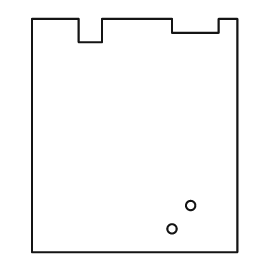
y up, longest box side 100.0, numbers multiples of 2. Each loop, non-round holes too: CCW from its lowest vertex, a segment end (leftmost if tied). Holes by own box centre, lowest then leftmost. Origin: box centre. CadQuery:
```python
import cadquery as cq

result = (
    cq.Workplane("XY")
    .moveTo(-44.0, -50.0)
    .lineTo(44.0, -50.0)
    .lineTo(44.0, 50.0)
    .lineTo(36.0, 50.0)
    .lineTo(36.0, 44.0)
    .lineTo(16.0, 44.0)
    .lineTo(16.0, 50.0)
    .lineTo(-14.0, 50.0)
    .lineTo(-14.0, 40.0)
    .lineTo(-24.0, 40.0)
    .lineTo(-24.0, 50.0)
    .lineTo(-44.0, 50.0)
    .close()
    .moveTo(16.0, -40.0)
    .circle(2.0)
    .moveTo(24.0, -30.0)
    .circle(2.0)
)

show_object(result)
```